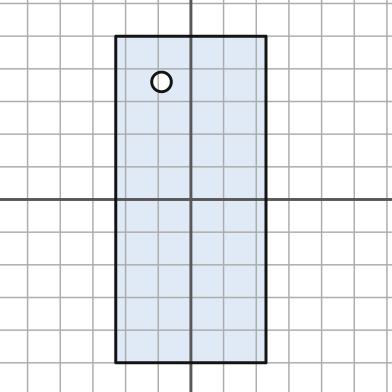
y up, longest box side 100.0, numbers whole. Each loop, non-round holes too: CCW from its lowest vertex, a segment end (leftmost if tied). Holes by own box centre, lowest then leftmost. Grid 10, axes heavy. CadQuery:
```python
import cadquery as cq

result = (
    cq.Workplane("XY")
    .moveTo(-23.0, -50.0)
    .lineTo(23.0, -50.0)
    .lineTo(23.0, 50.0)
    .lineTo(-23.0, 50.0)
    .close()
    .moveTo(-9.0, 36.0)
    .circle(3.0)
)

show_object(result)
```